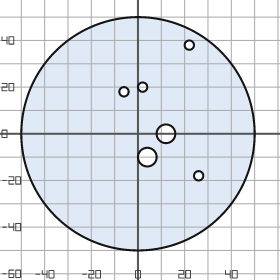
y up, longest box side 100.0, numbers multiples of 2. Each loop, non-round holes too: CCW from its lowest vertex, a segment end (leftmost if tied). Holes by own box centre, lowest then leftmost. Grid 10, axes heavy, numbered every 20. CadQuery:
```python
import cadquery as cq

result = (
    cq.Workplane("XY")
    .moveTo(0.0, 0.0)
    .circle(50.0)
    .moveTo(26.0, -18.0)
    .circle(2.0)
    .moveTo(4.0, -10.0)
    .circle(4.0)
    .moveTo(12.0, 0.0)
    .circle(4.0)
    .moveTo(-6.0, 18.0)
    .circle(2.0)
    .moveTo(2.0, 20.0)
    .circle(2.0)
    .moveTo(22.0, 38.0)
    .circle(2.0)
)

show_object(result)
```